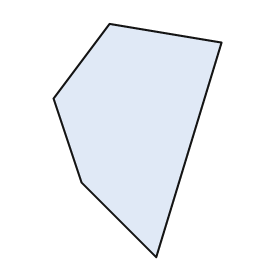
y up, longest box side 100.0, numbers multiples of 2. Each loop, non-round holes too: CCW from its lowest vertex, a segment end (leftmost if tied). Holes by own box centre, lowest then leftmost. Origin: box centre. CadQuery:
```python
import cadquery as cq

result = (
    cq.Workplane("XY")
    .moveTo(8.0, -50.0)
    .lineTo(36.0, 42.0)
    .lineTo(-12.0, 50.0)
    .lineTo(-36.0, 18.0)
    .lineTo(-24.0, -18.0)
    .close()
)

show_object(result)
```